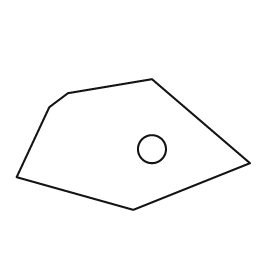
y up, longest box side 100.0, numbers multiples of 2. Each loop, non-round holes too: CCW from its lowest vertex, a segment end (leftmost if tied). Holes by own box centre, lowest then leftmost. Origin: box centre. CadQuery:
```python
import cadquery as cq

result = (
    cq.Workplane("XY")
    .moveTo(0.0, -28.0)
    .lineTo(50.0, -8.0)
    .lineTo(8.0, 28.0)
    .lineTo(-28.0, 22.0)
    .lineTo(-36.0, 16.0)
    .lineTo(-50.0, -14.0)
    .close()
    .moveTo(8.0, -2.0)
    .circle(6.0)
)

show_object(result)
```